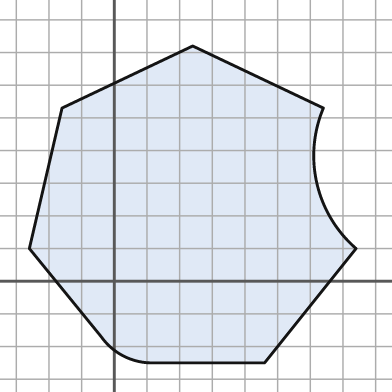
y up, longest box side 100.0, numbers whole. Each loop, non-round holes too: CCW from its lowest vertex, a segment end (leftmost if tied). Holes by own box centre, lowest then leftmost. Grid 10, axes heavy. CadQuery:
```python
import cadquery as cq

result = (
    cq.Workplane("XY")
    .moveTo(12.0, -25.0)
    .lineTo(46.0, -25.0)
    .lineTo(74.0, 10.0)
    .threePointArc((62.0, 30.0), (64.0, 53.0))
    .lineTo(24.0, 72.0)
    .lineTo(-16.0, 53.0)
    .lineTo(-26.0, 10.0)
    .lineTo(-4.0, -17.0)
    .threePointArc((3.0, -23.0), (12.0, -25.0))
    .close()
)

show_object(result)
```